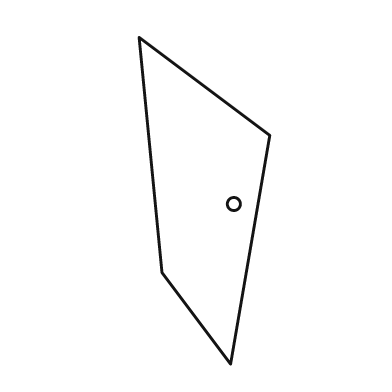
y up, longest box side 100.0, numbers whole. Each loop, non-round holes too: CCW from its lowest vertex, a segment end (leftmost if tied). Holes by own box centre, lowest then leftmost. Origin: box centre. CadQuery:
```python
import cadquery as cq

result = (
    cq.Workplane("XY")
    .moveTo(8.0, -50.0)
    .lineTo(20.0, 20.0)
    .lineTo(-20.0, 50.0)
    .lineTo(-13.0, -22.0)
    .close()
    .moveTo(9.0, -1.0)
    .circle(2.0)
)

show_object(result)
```